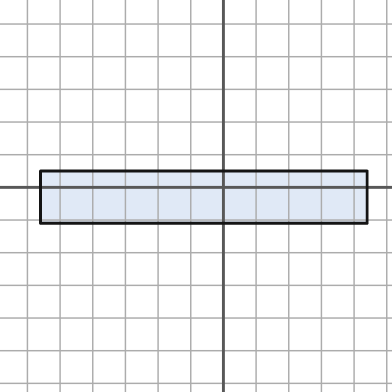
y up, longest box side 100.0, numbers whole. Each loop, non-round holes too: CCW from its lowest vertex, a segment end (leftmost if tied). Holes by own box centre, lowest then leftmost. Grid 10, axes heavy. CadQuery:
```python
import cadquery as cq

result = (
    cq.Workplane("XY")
    .moveTo(-56.0, -11.0)
    .lineTo(44.0, -11.0)
    .lineTo(44.0, 5.0)
    .lineTo(-56.0, 5.0)
    .close()
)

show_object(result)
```